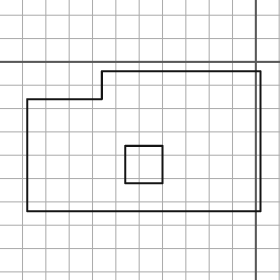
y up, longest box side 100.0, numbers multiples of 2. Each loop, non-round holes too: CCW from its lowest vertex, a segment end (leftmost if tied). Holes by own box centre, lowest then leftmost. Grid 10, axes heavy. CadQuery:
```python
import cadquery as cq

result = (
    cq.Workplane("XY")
    .moveTo(-98.0, -64.0)
    .lineTo(2.0, -64.0)
    .lineTo(2.0, -4.0)
    .lineTo(-66.0, -4.0)
    .lineTo(-66.0, -16.0)
    .lineTo(-98.0, -16.0)
    .close()
    .moveTo(-56.0, -52.0)
    .lineTo(-40.0, -52.0)
    .lineTo(-40.0, -36.0)
    .lineTo(-56.0, -36.0)
    .close()
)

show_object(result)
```